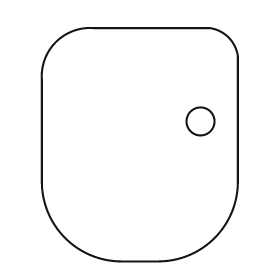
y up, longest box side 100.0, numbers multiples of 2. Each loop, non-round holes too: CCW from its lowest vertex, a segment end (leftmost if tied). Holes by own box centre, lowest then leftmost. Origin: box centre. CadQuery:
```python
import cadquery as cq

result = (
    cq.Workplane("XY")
    .moveTo(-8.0, -50.0)
    .lineTo(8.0, -50.0)
    .threePointArc((32.0, -40.0), (42.0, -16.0))
    .lineTo(42.0, 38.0)
    .threePointArc((38.0, 46.0), (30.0, 50.0))
    .lineTo(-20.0, 50.0)
    .threePointArc((-36.0, 44.0), (-42.0, 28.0))
    .lineTo(-42.0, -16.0)
    .threePointArc((-32.0, -40.0), (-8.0, -50.0))
    .close()
    .moveTo(26.0, 10.0)
    .circle(6.0)
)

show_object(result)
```